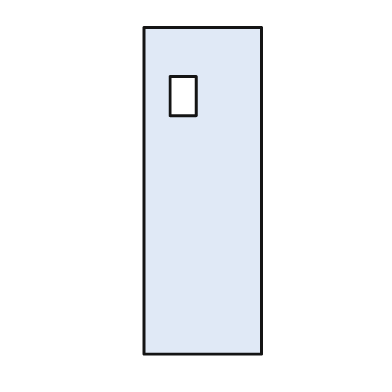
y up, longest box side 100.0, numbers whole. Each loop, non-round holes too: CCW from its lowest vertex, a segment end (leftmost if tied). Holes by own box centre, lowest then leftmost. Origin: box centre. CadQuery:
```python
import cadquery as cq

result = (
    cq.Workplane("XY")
    .moveTo(-18.0, -50.0)
    .lineTo(18.0, -50.0)
    .lineTo(18.0, 50.0)
    .lineTo(-18.0, 50.0)
    .close()
    .moveTo(-10.0, 23.0)
    .lineTo(-2.0, 23.0)
    .lineTo(-2.0, 35.0)
    .lineTo(-10.0, 35.0)
    .close()
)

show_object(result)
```